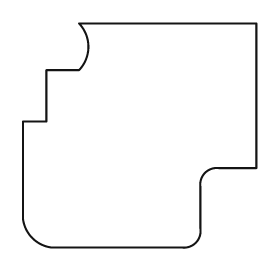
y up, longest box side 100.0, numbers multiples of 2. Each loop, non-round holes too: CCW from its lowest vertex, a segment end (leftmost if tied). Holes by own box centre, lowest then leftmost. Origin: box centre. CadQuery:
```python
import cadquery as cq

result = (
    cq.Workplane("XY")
    .moveTo(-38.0, -48.0)
    .lineTo(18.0, -48.0)
    .threePointArc((24.0, -46.0), (26.0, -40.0))
    .lineTo(26.0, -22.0)
    .threePointArc((28.0, -16.0), (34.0, -14.0))
    .lineTo(50.0, -14.0)
    .lineTo(50.0, 48.0)
    .lineTo(-26.0, 48.0)
    .threePointArc((-22.0, 38.0), (-26.0, 28.0))
    .lineTo(-40.0, 28.0)
    .lineTo(-40.0, 6.0)
    .lineTo(-50.0, 6.0)
    .lineTo(-50.0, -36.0)
    .threePointArc((-46.0, -44.0), (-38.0, -48.0))
    .close()
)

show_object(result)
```